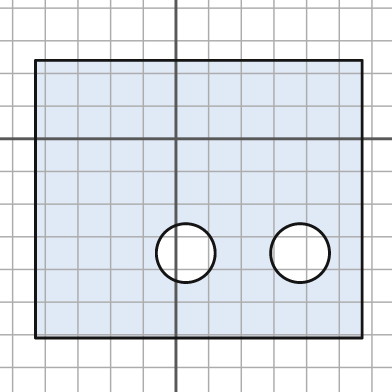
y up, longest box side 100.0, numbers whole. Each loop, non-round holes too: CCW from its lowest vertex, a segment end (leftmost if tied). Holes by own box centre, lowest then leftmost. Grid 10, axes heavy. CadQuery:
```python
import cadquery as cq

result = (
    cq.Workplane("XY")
    .moveTo(-43.0, -61.0)
    .lineTo(57.0, -61.0)
    .lineTo(57.0, 24.0)
    .lineTo(-43.0, 24.0)
    .close()
    .moveTo(3.0, -35.0)
    .circle(9.0)
    .moveTo(38.0, -35.0)
    .circle(9.0)
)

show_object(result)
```